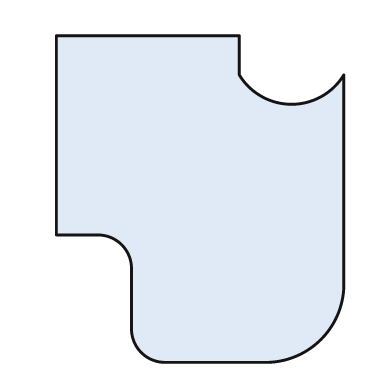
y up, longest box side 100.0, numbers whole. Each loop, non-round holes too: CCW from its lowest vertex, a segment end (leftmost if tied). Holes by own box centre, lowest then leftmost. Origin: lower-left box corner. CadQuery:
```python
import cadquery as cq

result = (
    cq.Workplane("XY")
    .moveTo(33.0, 0.0)
    .lineTo(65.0, 0.0)
    .threePointArc((81.0, 7.0), (88.0, 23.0))
    .lineTo(88.0, 88.0)
    .threePointArc((72.0, 79.0), (56.0, 88.0))
    .lineTo(56.0, 100.0)
    .lineTo(0.0, 100.0)
    .lineTo(0.0, 39.0)
    .lineTo(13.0, 39.0)
    .threePointArc((20.0, 36.0), (23.0, 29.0))
    .lineTo(23.0, 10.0)
    .threePointArc((26.0, 3.0), (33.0, 0.0))
    .close()
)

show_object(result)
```